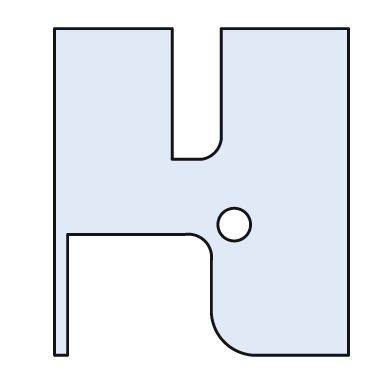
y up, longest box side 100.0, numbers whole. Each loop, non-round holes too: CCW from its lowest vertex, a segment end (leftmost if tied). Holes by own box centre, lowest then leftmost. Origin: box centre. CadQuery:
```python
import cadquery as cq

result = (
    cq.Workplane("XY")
    .moveTo(-45.0, -50.0)
    .lineTo(-41.0, -50.0)
    .lineTo(-41.0, -13.0)
    .lineTo(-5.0, -13.0)
    .threePointArc((1.0, -15.0), (3.0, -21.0))
    .lineTo(3.0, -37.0)
    .threePointArc((7.0, -46.0), (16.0, -50.0))
    .lineTo(45.0, -50.0)
    .lineTo(45.0, 50.0)
    .lineTo(6.0, 50.0)
    .lineTo(6.0, 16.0)
    .threePointArc((4.0, 12.0), (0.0, 10.0))
    .lineTo(-9.0, 10.0)
    .lineTo(-9.0, 50.0)
    .lineTo(-45.0, 50.0)
    .close()
    .moveTo(10.0, -10.0)
    .circle(5.0)
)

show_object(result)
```